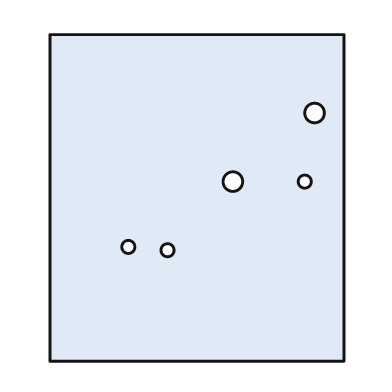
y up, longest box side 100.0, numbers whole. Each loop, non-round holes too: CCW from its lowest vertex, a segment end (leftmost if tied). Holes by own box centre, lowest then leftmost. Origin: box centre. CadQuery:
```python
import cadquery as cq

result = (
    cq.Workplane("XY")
    .moveTo(-45.0, -50.0)
    .lineTo(45.0, -50.0)
    .lineTo(45.0, 50.0)
    .lineTo(-45.0, 50.0)
    .close()
    .moveTo(-9.0, -16.0)
    .circle(2.0)
    .moveTo(-21.0, -15.0)
    .circle(2.0)
    .moveTo(11.0, 5.0)
    .circle(3.0)
    .moveTo(33.0, 5.0)
    .circle(2.0)
    .moveTo(36.0, 26.0)
    .circle(3.0)
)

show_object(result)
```